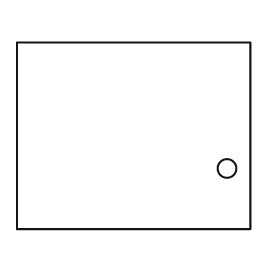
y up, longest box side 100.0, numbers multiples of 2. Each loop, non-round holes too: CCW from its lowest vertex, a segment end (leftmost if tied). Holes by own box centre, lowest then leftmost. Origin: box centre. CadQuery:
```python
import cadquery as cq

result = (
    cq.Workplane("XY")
    .moveTo(-50.0, -40.0)
    .lineTo(50.0, -40.0)
    .lineTo(50.0, 40.0)
    .lineTo(-50.0, 40.0)
    .close()
    .moveTo(40.0, -14.0)
    .circle(4.0)
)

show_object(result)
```